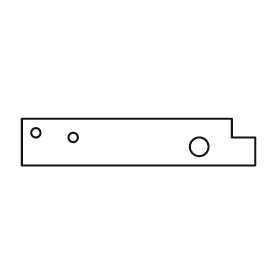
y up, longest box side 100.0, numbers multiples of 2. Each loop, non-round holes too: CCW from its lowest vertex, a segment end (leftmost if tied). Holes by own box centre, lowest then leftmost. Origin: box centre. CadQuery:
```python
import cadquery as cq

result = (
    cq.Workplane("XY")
    .moveTo(-50.0, -10.0)
    .lineTo(50.0, -10.0)
    .lineTo(50.0, 2.0)
    .lineTo(40.0, 2.0)
    .lineTo(40.0, 10.0)
    .lineTo(-50.0, 10.0)
    .close()
    .moveTo(26.0, -2.0)
    .circle(4.0)
    .moveTo(-28.0, 2.0)
    .circle(2.0)
    .moveTo(-44.0, 4.0)
    .circle(2.0)
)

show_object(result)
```